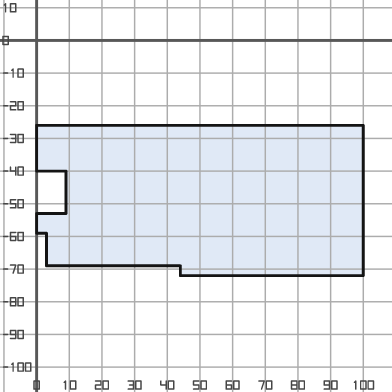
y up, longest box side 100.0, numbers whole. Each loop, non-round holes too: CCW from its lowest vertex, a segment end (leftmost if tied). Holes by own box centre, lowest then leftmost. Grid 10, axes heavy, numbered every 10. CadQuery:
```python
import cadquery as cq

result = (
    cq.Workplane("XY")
    .moveTo(44.0, -72.0)
    .lineTo(100.0, -72.0)
    .lineTo(100.0, -26.0)
    .lineTo(0.0, -26.0)
    .lineTo(0.0, -40.0)
    .lineTo(9.0, -40.0)
    .lineTo(9.0, -53.0)
    .lineTo(0.0, -53.0)
    .lineTo(0.0, -59.0)
    .lineTo(3.0, -59.0)
    .lineTo(3.0, -69.0)
    .lineTo(44.0, -69.0)
    .close()
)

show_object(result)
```